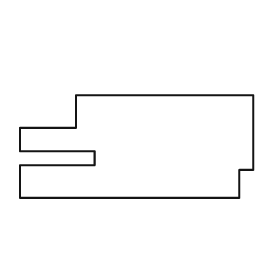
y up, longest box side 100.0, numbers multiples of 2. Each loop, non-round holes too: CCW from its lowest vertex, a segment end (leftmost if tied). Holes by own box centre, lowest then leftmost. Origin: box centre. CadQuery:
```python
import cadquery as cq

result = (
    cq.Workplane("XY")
    .moveTo(-50.0, -22.0)
    .lineTo(44.0, -22.0)
    .lineTo(44.0, -10.0)
    .lineTo(50.0, -10.0)
    .lineTo(50.0, 22.0)
    .lineTo(-26.0, 22.0)
    .lineTo(-26.0, 8.0)
    .lineTo(-50.0, 8.0)
    .lineTo(-50.0, -2.0)
    .lineTo(-18.0, -2.0)
    .lineTo(-18.0, -8.0)
    .lineTo(-50.0, -8.0)
    .close()
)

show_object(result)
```